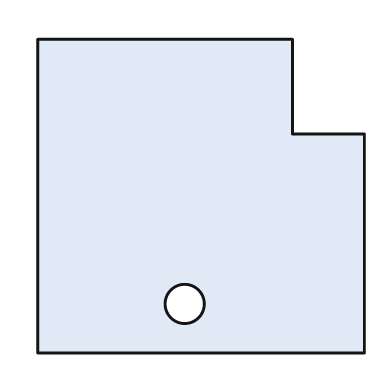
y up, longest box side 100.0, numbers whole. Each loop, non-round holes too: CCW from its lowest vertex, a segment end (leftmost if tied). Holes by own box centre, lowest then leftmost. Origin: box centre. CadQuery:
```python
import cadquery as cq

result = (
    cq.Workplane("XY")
    .moveTo(-50.0, -48.0)
    .lineTo(50.0, -48.0)
    .lineTo(50.0, 19.0)
    .lineTo(28.0, 19.0)
    .lineTo(28.0, 48.0)
    .lineTo(-50.0, 48.0)
    .close()
    .moveTo(-5.0, -33.0)
    .circle(6.0)
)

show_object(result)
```